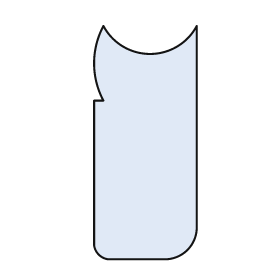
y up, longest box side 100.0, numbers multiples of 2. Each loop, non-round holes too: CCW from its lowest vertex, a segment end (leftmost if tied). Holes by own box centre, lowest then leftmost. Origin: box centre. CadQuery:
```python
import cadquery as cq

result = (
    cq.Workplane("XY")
    .moveTo(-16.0, -50.0)
    .lineTo(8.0, -50.0)
    .threePointArc((18.0, -46.0), (22.0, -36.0))
    .lineTo(22.0, 50.0)
    .threePointArc((2.0, 38.0), (-18.0, 50.0))
    .threePointArc((-22.0, 34.0), (-18.0, 18.0))
    .lineTo(-22.0, 18.0)
    .lineTo(-22.0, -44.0)
    .threePointArc((-20.0, -48.0), (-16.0, -50.0))
    .close()
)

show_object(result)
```